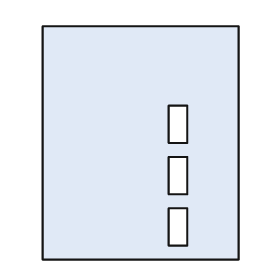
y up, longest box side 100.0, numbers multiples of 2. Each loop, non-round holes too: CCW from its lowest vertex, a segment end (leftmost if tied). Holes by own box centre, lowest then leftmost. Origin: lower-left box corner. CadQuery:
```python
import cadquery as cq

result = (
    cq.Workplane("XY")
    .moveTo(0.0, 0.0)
    .lineTo(84.0, 0.0)
    .lineTo(84.0, 100.0)
    .lineTo(0.0, 100.0)
    .close()
    .moveTo(54.0, 6.0)
    .lineTo(62.0, 6.0)
    .lineTo(62.0, 22.0)
    .lineTo(54.0, 22.0)
    .close()
    .moveTo(54.0, 28.0)
    .lineTo(62.0, 28.0)
    .lineTo(62.0, 44.0)
    .lineTo(54.0, 44.0)
    .close()
    .moveTo(54.0, 50.0)
    .lineTo(62.0, 50.0)
    .lineTo(62.0, 66.0)
    .lineTo(54.0, 66.0)
    .close()
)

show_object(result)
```